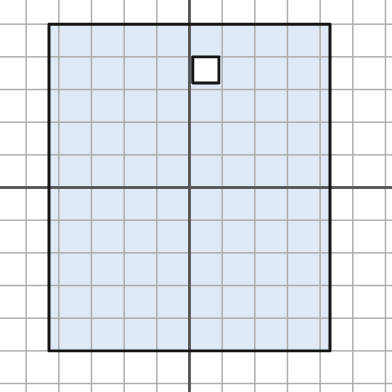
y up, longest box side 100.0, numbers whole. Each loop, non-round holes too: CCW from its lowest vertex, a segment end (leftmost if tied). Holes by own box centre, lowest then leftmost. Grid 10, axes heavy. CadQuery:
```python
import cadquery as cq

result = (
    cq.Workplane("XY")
    .moveTo(-43.0, -50.0)
    .lineTo(43.0, -50.0)
    .lineTo(43.0, 50.0)
    .lineTo(-43.0, 50.0)
    .close()
    .moveTo(1.0, 32.0)
    .lineTo(9.0, 32.0)
    .lineTo(9.0, 40.0)
    .lineTo(1.0, 40.0)
    .close()
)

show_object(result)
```